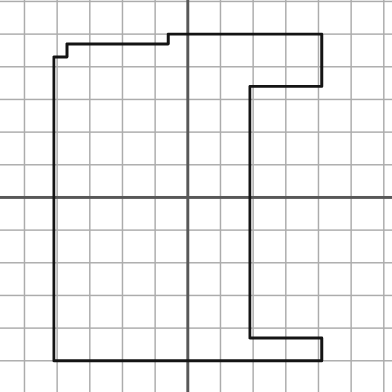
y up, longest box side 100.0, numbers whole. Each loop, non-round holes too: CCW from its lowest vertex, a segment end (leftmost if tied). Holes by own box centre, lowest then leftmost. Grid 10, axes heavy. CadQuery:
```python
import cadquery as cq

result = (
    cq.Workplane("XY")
    .moveTo(-41.0, -50.0)
    .lineTo(41.0, -50.0)
    .lineTo(41.0, -43.0)
    .lineTo(19.0, -43.0)
    .lineTo(19.0, 34.0)
    .lineTo(41.0, 34.0)
    .lineTo(41.0, 50.0)
    .lineTo(-6.0, 50.0)
    .lineTo(-6.0, 47.0)
    .lineTo(-37.0, 47.0)
    .lineTo(-37.0, 43.0)
    .lineTo(-41.0, 43.0)
    .close()
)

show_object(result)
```